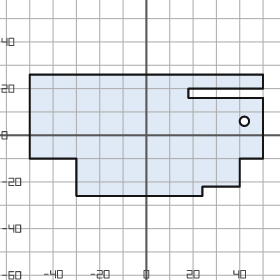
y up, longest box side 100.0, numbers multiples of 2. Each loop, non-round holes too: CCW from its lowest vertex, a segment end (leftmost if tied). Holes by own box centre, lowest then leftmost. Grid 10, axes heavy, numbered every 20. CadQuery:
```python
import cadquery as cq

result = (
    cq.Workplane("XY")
    .moveTo(-30.0, -26.0)
    .lineTo(24.0, -26.0)
    .lineTo(24.0, -22.0)
    .lineTo(40.0, -22.0)
    .lineTo(40.0, -10.0)
    .lineTo(50.0, -10.0)
    .lineTo(50.0, 16.0)
    .lineTo(18.0, 16.0)
    .lineTo(18.0, 20.0)
    .lineTo(50.0, 20.0)
    .lineTo(50.0, 26.0)
    .lineTo(-50.0, 26.0)
    .lineTo(-50.0, -10.0)
    .lineTo(-30.0, -10.0)
    .close()
    .moveTo(42.0, 6.0)
    .circle(2.0)
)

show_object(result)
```